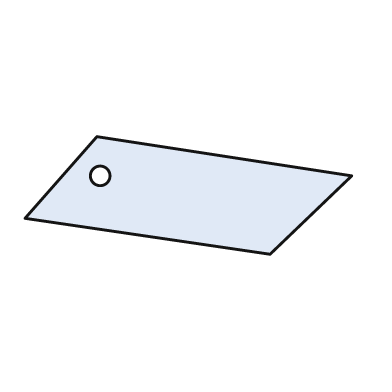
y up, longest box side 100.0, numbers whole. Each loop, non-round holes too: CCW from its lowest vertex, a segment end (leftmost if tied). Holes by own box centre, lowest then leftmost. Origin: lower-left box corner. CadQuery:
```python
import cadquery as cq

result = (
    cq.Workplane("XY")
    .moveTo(75.0, 0.0)
    .lineTo(100.0, 24.0)
    .lineTo(22.0, 36.0)
    .lineTo(0.0, 11.0)
    .close()
    .moveTo(23.0, 24.0)
    .circle(3.0)
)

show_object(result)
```